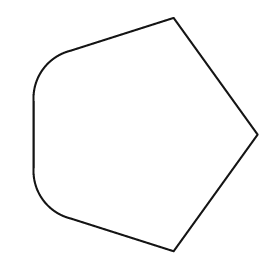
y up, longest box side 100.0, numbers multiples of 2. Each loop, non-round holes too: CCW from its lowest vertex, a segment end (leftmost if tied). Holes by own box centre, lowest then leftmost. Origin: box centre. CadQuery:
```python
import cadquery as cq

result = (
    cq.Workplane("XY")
    .moveTo(12.0, -50.0)
    .lineTo(48.0, 0.0)
    .lineTo(12.0, 50.0)
    .lineTo(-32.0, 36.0)
    .threePointArc((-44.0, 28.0), (-48.0, 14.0))
    .lineTo(-48.0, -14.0)
    .threePointArc((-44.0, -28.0), (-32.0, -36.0))
    .close()
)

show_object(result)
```